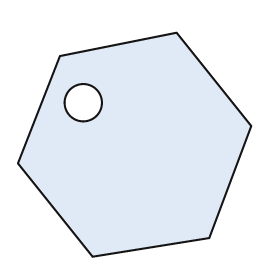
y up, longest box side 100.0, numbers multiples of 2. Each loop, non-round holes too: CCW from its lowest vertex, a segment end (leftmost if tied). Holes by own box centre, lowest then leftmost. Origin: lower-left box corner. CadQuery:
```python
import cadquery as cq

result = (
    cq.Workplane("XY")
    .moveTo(32.0, 0.0)
    .lineTo(82.0, 8.0)
    .lineTo(100.0, 56.0)
    .lineTo(68.0, 96.0)
    .lineTo(18.0, 86.0)
    .lineTo(0.0, 40.0)
    .close()
    .moveTo(28.0, 66.0)
    .circle(8.0)
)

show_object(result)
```